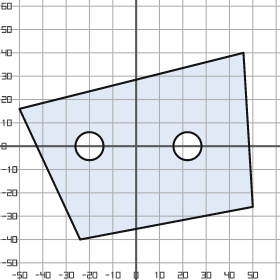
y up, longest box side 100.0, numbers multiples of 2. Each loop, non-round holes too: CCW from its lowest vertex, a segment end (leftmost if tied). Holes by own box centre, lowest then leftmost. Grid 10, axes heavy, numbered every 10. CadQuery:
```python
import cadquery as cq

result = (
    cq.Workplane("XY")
    .moveTo(-24.0, -40.0)
    .lineTo(50.0, -26.0)
    .lineTo(46.0, 40.0)
    .lineTo(-50.0, 16.0)
    .close()
    .moveTo(-20.0, 0.0)
    .circle(6.0)
    .moveTo(22.0, 0.0)
    .circle(6.0)
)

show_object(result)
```